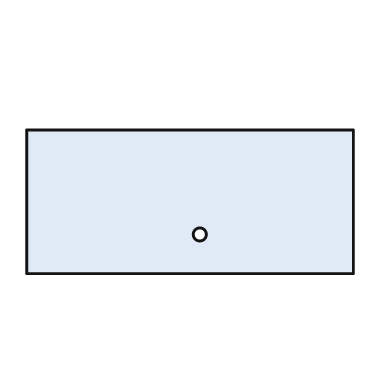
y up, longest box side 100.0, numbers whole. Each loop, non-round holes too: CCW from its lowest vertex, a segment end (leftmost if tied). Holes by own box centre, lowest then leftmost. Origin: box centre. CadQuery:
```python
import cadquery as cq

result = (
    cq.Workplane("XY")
    .moveTo(-50.0, -22.0)
    .lineTo(50.0, -22.0)
    .lineTo(50.0, 22.0)
    .lineTo(-50.0, 22.0)
    .close()
    .moveTo(3.0, -10.0)
    .circle(2.0)
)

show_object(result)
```